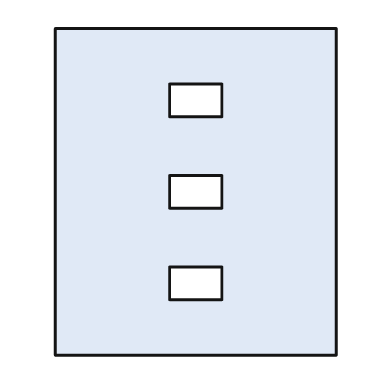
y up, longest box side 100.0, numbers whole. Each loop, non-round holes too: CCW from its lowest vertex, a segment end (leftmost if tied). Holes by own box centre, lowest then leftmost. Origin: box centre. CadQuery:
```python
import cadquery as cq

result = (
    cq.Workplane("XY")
    .moveTo(-43.0, -50.0)
    .lineTo(43.0, -50.0)
    .lineTo(43.0, 50.0)
    .lineTo(-43.0, 50.0)
    .close()
    .moveTo(-8.0, -33.0)
    .lineTo(8.0, -33.0)
    .lineTo(8.0, -23.0)
    .lineTo(-8.0, -23.0)
    .close()
    .moveTo(-8.0, -5.0)
    .lineTo(8.0, -5.0)
    .lineTo(8.0, 5.0)
    .lineTo(-8.0, 5.0)
    .close()
    .moveTo(-8.0, 23.0)
    .lineTo(8.0, 23.0)
    .lineTo(8.0, 33.0)
    .lineTo(-8.0, 33.0)
    .close()
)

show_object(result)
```